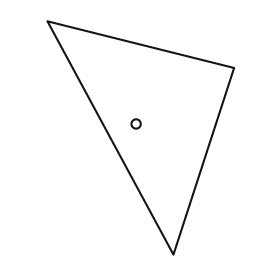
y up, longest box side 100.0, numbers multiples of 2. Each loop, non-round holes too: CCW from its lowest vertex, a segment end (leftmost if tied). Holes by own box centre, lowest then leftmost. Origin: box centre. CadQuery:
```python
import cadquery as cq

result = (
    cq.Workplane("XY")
    .moveTo(14.0, -50.0)
    .lineTo(40.0, 30.0)
    .lineTo(-40.0, 50.0)
    .close()
    .moveTo(-2.0, 6.0)
    .circle(2.0)
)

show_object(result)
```